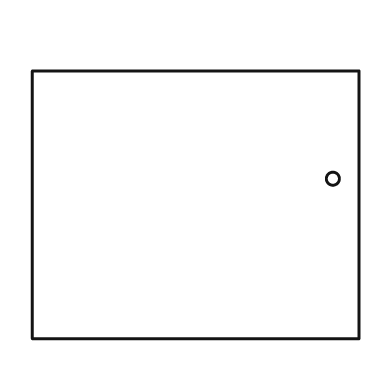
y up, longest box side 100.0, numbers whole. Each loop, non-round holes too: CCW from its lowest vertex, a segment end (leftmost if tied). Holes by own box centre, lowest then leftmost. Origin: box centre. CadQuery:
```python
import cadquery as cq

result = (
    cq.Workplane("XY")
    .moveTo(-50.0, -41.0)
    .lineTo(50.0, -41.0)
    .lineTo(50.0, 41.0)
    .lineTo(-50.0, 41.0)
    .close()
    .moveTo(42.0, 8.0)
    .circle(2.0)
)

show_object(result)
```